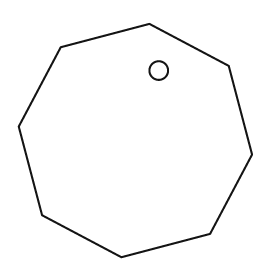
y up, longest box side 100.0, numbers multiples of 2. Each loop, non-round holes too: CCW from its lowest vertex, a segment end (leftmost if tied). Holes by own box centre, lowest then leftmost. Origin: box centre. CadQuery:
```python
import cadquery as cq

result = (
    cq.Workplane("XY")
    .moveTo(-6.0, -50.0)
    .lineTo(32.0, -40.0)
    .lineTo(50.0, -6.0)
    .lineTo(40.0, 32.0)
    .lineTo(6.0, 50.0)
    .lineTo(-32.0, 40.0)
    .lineTo(-50.0, 6.0)
    .lineTo(-40.0, -32.0)
    .close()
    .moveTo(10.0, 30.0)
    .circle(4.0)
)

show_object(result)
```